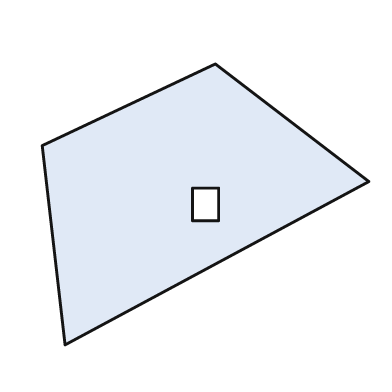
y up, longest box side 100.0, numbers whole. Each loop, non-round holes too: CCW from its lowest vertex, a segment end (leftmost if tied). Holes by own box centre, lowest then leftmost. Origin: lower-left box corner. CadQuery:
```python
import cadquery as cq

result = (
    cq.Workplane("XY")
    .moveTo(7.0, 0.0)
    .lineTo(100.0, 50.0)
    .lineTo(53.0, 86.0)
    .lineTo(0.0, 61.0)
    .close()
    .moveTo(46.0, 38.0)
    .lineTo(54.0, 38.0)
    .lineTo(54.0, 48.0)
    .lineTo(46.0, 48.0)
    .close()
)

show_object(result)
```